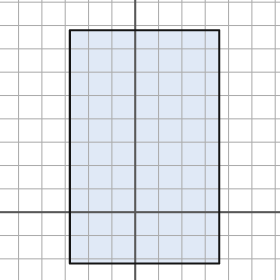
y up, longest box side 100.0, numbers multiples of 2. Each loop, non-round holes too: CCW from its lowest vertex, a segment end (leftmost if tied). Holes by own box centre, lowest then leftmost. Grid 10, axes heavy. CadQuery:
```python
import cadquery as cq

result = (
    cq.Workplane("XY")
    .moveTo(-28.0, -22.0)
    .lineTo(36.0, -22.0)
    .lineTo(36.0, 78.0)
    .lineTo(-28.0, 78.0)
    .close()
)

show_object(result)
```